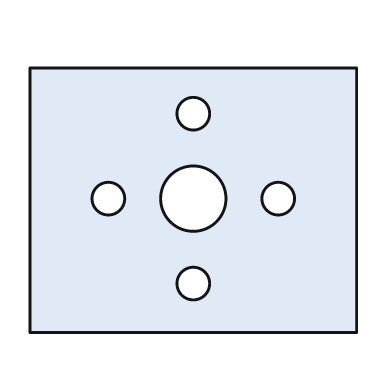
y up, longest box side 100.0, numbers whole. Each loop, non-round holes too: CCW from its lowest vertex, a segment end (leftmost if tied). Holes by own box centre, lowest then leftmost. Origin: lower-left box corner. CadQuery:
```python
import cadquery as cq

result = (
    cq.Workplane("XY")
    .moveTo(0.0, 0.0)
    .lineTo(100.0, 0.0)
    .lineTo(100.0, 81.0)
    .lineTo(0.0, 81.0)
    .close()
    .moveTo(50.0, 15.0)
    .circle(5.0)
    .moveTo(24.0, 41.0)
    .circle(5.0)
    .moveTo(50.0, 41.0)
    .circle(10.0)
    .moveTo(76.0, 41.0)
    .circle(5.0)
    .moveTo(50.0, 67.0)
    .circle(5.0)
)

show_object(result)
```